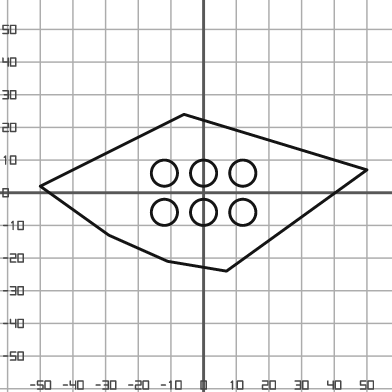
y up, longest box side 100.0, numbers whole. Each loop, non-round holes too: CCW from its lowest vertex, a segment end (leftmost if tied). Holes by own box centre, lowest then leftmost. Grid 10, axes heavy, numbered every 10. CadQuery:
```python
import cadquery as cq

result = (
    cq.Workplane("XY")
    .moveTo(7.0, -24.0)
    .lineTo(50.0, 7.0)
    .lineTo(-6.0, 24.0)
    .lineTo(-50.0, 2.0)
    .lineTo(-29.0, -13.0)
    .lineTo(-11.0, -21.0)
    .close()
    .moveTo(-12.0, -6.0)
    .circle(4.0)
    .moveTo(0.0, -6.0)
    .circle(4.0)
    .moveTo(12.0, -6.0)
    .circle(4.0)
    .moveTo(-12.0, 6.0)
    .circle(4.0)
    .moveTo(0.0, 6.0)
    .circle(4.0)
    .moveTo(12.0, 6.0)
    .circle(4.0)
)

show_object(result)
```